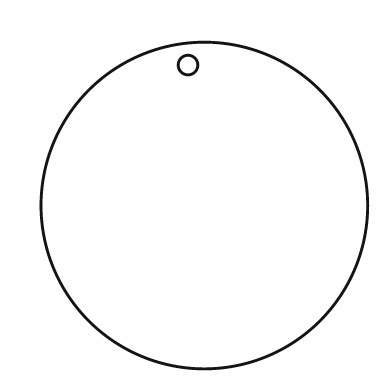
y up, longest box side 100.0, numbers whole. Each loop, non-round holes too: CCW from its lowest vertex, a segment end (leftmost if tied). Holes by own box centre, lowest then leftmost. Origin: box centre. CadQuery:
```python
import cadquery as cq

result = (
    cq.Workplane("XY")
    .moveTo(0.0, 0.0)
    .circle(50.0)
    .moveTo(-5.0, 43.0)
    .circle(3.0)
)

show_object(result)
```